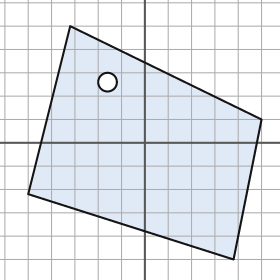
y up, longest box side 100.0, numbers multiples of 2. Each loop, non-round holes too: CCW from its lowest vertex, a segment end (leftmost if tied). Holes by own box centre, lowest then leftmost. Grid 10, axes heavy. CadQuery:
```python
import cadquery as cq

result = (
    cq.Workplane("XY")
    .moveTo(38.0, -50.0)
    .lineTo(50.0, 10.0)
    .lineTo(-32.0, 50.0)
    .lineTo(-50.0, -22.0)
    .close()
    .moveTo(-16.0, 26.0)
    .circle(4.0)
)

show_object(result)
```